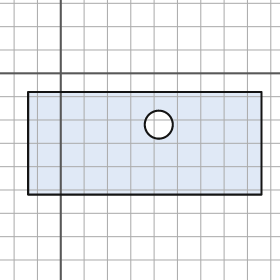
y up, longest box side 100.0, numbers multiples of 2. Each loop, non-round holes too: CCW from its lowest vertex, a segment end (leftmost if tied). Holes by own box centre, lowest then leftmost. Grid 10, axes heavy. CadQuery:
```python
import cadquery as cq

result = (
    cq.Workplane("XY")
    .moveTo(-14.0, -52.0)
    .lineTo(86.0, -52.0)
    .lineTo(86.0, -8.0)
    .lineTo(-14.0, -8.0)
    .close()
    .moveTo(42.0, -22.0)
    .circle(6.0)
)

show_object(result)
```